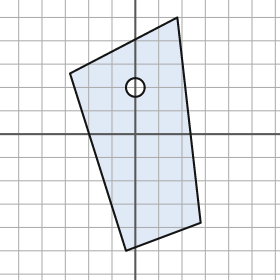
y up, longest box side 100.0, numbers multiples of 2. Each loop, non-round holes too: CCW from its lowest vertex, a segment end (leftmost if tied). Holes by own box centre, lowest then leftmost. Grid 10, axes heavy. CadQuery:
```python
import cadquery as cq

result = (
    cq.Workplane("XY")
    .moveTo(-4.0, -50.0)
    .lineTo(28.0, -38.0)
    .lineTo(18.0, 50.0)
    .lineTo(-28.0, 26.0)
    .close()
    .moveTo(0.0, 20.0)
    .circle(4.0)
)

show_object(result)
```